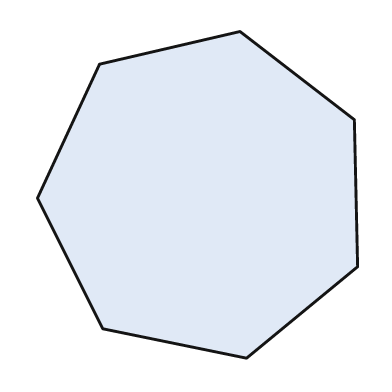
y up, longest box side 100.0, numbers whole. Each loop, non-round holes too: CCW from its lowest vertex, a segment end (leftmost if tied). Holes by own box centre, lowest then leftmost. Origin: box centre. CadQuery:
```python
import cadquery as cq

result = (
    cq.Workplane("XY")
    .moveTo(15.0, -50.0)
    .lineTo(49.0, -22.0)
    .lineTo(48.0, 23.0)
    .lineTo(13.0, 50.0)
    .lineTo(-30.0, 40.0)
    .lineTo(-49.0, -1.0)
    .lineTo(-29.0, -41.0)
    .close()
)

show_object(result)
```